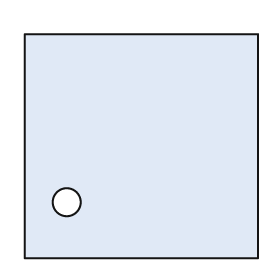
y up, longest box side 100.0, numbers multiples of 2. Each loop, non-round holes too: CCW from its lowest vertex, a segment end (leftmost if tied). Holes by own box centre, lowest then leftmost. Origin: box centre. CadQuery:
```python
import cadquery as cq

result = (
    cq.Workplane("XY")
    .moveTo(-50.0, -48.0)
    .lineTo(50.0, -48.0)
    .lineTo(50.0, 48.0)
    .lineTo(-50.0, 48.0)
    .close()
    .moveTo(-32.0, -24.0)
    .circle(6.0)
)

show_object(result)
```